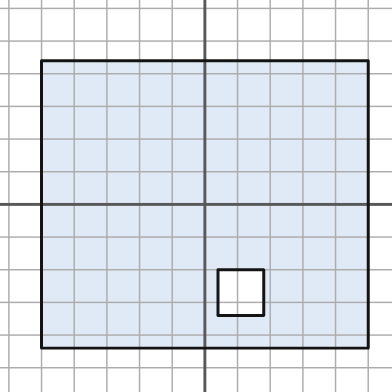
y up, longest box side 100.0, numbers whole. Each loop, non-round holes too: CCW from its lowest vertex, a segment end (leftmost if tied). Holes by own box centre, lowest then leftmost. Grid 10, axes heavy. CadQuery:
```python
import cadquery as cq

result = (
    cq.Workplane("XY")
    .moveTo(-50.0, -44.0)
    .lineTo(50.0, -44.0)
    .lineTo(50.0, 44.0)
    .lineTo(-50.0, 44.0)
    .close()
    .moveTo(4.0, -34.0)
    .lineTo(18.0, -34.0)
    .lineTo(18.0, -20.0)
    .lineTo(4.0, -20.0)
    .close()
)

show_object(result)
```